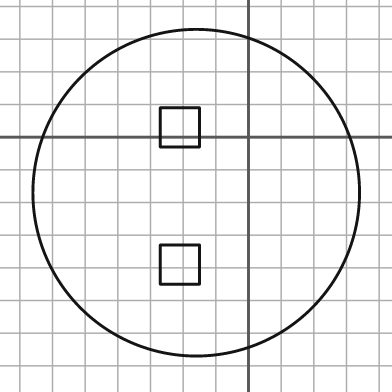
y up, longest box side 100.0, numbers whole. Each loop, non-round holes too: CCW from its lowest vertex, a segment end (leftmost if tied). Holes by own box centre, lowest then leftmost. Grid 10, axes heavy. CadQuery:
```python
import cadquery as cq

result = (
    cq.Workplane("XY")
    .moveTo(-16.0, -17.0)
    .circle(50.0)
    .moveTo(-27.0, -45.0)
    .lineTo(-15.0, -45.0)
    .lineTo(-15.0, -33.0)
    .lineTo(-27.0, -33.0)
    .close()
    .moveTo(-27.0, -3.0)
    .lineTo(-15.0, -3.0)
    .lineTo(-15.0, 9.0)
    .lineTo(-27.0, 9.0)
    .close()
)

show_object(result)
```